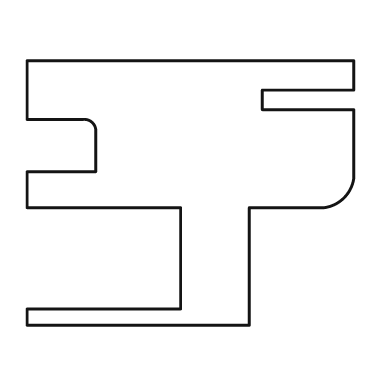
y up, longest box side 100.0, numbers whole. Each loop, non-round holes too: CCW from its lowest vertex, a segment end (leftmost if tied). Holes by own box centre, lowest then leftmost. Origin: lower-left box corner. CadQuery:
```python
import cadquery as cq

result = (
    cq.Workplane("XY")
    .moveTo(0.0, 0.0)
    .lineTo(68.0, 0.0)
    .lineTo(68.0, 36.0)
    .lineTo(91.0, 36.0)
    .threePointArc((97.0, 39.0), (100.0, 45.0))
    .lineTo(100.0, 66.0)
    .lineTo(72.0, 66.0)
    .lineTo(72.0, 72.0)
    .lineTo(100.0, 72.0)
    .lineTo(100.0, 81.0)
    .lineTo(0.0, 81.0)
    .lineTo(0.0, 63.0)
    .lineTo(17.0, 63.0)
    .threePointArc((20.0, 62.0), (21.0, 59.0))
    .lineTo(21.0, 47.0)
    .lineTo(0.0, 47.0)
    .lineTo(0.0, 36.0)
    .lineTo(47.0, 36.0)
    .lineTo(47.0, 5.0)
    .lineTo(0.0, 5.0)
    .close()
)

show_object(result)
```